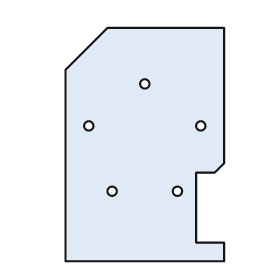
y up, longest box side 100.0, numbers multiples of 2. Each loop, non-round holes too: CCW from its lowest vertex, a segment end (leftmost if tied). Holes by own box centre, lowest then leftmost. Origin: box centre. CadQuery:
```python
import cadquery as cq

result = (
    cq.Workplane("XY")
    .moveTo(-34.0, -50.0)
    .lineTo(34.0, -50.0)
    .lineTo(34.0, -42.0)
    .lineTo(22.0, -42.0)
    .lineTo(22.0, -12.0)
    .lineTo(30.0, -12.0)
    .lineTo(34.0, -8.0)
    .lineTo(34.0, 50.0)
    .lineTo(-16.0, 50.0)
    .lineTo(-34.0, 32.0)
    .close()
    .moveTo(-14.0, -20.0)
    .circle(2.0)
    .moveTo(14.0, -20.0)
    .circle(2.0)
    .moveTo(-24.0, 8.0)
    .circle(2.0)
    .moveTo(24.0, 8.0)
    .circle(2.0)
    .moveTo(0.0, 26.0)
    .circle(2.0)
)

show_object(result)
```